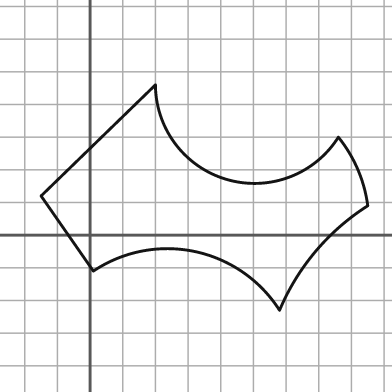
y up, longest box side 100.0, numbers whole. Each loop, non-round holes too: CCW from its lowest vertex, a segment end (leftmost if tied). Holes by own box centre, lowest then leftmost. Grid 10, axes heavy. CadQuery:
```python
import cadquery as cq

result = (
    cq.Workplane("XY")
    .moveTo(58.0, -23.0)
    .threePointArc((69.0, -5.0), (85.0, 9.0))
    .threePointArc((82.0, 20.0), (76.0, 30.0))
    .threePointArc((42.0, 17.0), (20.0, 46.0))
    .lineTo(-15.0, 12.0)
    .lineTo(1.0, -11.0)
    .threePointArc((32.0, -5.0), (58.0, -23.0))
    .close()
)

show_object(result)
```